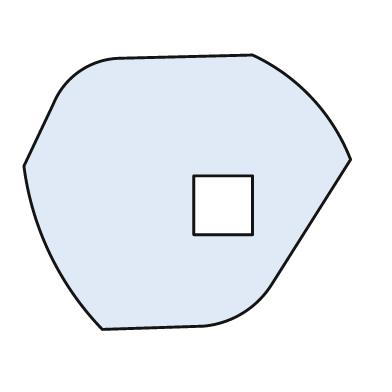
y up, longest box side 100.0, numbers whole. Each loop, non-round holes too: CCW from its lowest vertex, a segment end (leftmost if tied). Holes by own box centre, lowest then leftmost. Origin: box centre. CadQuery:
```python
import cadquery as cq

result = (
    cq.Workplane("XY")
    .moveTo(-26.0, -42.0)
    .lineTo(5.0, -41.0)
    .threePointArc((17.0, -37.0), (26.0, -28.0))
    .lineTo(50.0, 10.0)
    .threePointArc((38.0, 29.0), (20.0, 42.0))
    .lineTo(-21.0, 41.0)
    .threePointArc((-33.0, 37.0), (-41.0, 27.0))
    .lineTo(-50.0, 8.0)
    .threePointArc((-42.0, -19.0), (-26.0, -42.0))
    .close()
    .moveTo(2.0, -13.0)
    .lineTo(20.0, -13.0)
    .lineTo(20.0, 5.0)
    .lineTo(2.0, 5.0)
    .close()
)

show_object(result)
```